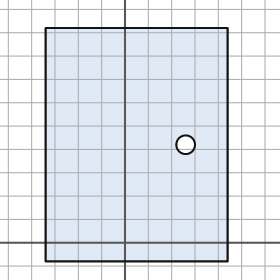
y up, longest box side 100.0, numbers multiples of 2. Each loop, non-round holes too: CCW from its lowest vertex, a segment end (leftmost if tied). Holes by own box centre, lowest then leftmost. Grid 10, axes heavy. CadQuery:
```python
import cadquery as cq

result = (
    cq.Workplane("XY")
    .moveTo(-34.0, -8.0)
    .lineTo(44.0, -8.0)
    .lineTo(44.0, 92.0)
    .lineTo(-34.0, 92.0)
    .close()
    .moveTo(26.0, 42.0)
    .circle(4.0)
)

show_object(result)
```